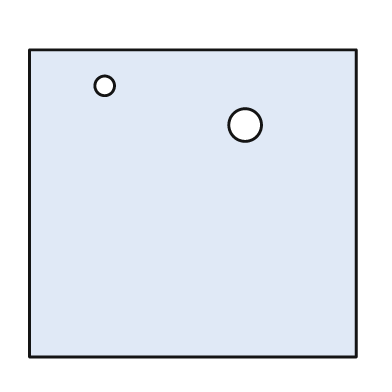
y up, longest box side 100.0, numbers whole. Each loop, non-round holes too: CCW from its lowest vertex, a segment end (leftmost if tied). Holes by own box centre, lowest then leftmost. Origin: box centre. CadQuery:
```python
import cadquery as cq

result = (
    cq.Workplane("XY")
    .moveTo(-50.0, -47.0)
    .lineTo(50.0, -47.0)
    .lineTo(50.0, 47.0)
    .lineTo(-50.0, 47.0)
    .close()
    .moveTo(16.0, 24.0)
    .circle(5.0)
    .moveTo(-27.0, 36.0)
    .circle(3.0)
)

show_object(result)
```